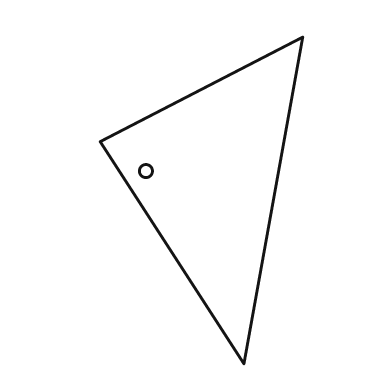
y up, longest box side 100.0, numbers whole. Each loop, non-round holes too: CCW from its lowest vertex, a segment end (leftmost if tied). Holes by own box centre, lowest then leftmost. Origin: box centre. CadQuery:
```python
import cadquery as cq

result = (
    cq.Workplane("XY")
    .moveTo(13.0, -50.0)
    .lineTo(31.0, 50.0)
    .lineTo(-31.0, 18.0)
    .close()
    .moveTo(-17.0, 9.0)
    .circle(2.0)
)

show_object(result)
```